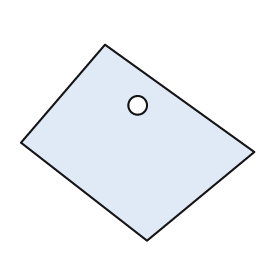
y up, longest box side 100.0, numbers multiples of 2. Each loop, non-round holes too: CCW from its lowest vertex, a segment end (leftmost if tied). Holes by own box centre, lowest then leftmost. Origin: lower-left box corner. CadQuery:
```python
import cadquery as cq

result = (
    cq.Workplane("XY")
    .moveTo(54.0, 0.0)
    .lineTo(100.0, 38.0)
    .lineTo(36.0, 84.0)
    .lineTo(0.0, 42.0)
    .close()
    .moveTo(50.0, 58.0)
    .circle(4.0)
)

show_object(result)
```